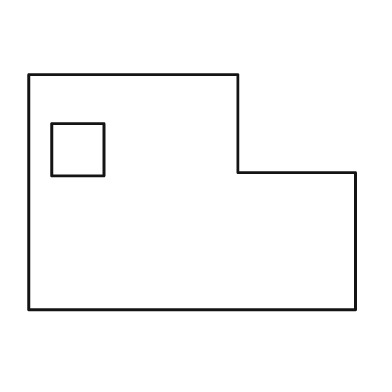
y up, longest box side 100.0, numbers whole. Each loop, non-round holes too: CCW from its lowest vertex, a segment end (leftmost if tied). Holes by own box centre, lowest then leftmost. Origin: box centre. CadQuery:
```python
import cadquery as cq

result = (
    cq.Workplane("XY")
    .moveTo(-50.0, -36.0)
    .lineTo(50.0, -36.0)
    .lineTo(50.0, 6.0)
    .lineTo(14.0, 6.0)
    .lineTo(14.0, 36.0)
    .lineTo(-50.0, 36.0)
    .close()
    .moveTo(-43.0, 5.0)
    .lineTo(-27.0, 5.0)
    .lineTo(-27.0, 21.0)
    .lineTo(-43.0, 21.0)
    .close()
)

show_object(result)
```